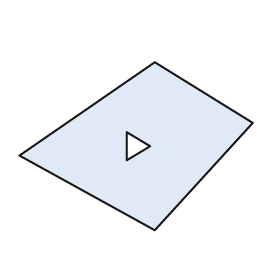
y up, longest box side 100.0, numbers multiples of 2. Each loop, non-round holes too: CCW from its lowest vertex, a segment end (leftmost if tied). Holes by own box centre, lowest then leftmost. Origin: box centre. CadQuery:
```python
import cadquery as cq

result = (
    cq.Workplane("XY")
    .moveTo(8.0, -36.0)
    .lineTo(50.0, 10.0)
    .lineTo(8.0, 36.0)
    .lineTo(-50.0, -4.0)
    .close()
    .moveTo(-4.0, -6.0)
    .lineTo(6.0, 0.0)
    .lineTo(-4.0, 6.0)
    .close()
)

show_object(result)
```